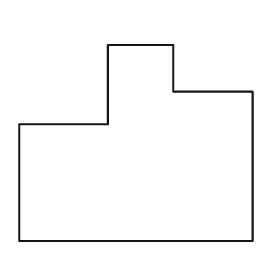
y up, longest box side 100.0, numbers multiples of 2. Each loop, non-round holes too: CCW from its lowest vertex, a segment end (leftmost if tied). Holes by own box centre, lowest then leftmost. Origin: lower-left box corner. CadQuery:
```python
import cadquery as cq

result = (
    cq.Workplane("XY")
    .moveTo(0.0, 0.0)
    .lineTo(100.0, 0.0)
    .lineTo(100.0, 64.0)
    .lineTo(66.0, 64.0)
    .lineTo(66.0, 84.0)
    .lineTo(38.0, 84.0)
    .lineTo(38.0, 50.0)
    .lineTo(0.0, 50.0)
    .close()
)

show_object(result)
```